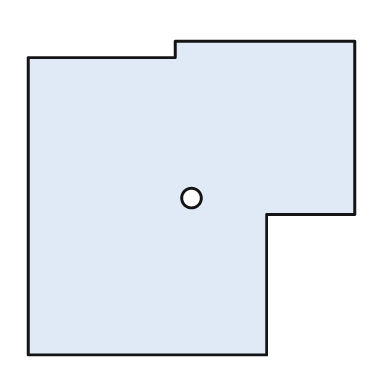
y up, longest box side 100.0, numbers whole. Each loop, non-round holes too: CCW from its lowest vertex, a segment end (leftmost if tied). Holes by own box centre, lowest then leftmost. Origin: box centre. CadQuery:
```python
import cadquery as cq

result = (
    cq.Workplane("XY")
    .moveTo(-50.0, -48.0)
    .lineTo(23.0, -48.0)
    .lineTo(23.0, -5.0)
    .lineTo(50.0, -5.0)
    .lineTo(50.0, 48.0)
    .lineTo(-5.0, 48.0)
    .lineTo(-5.0, 43.0)
    .lineTo(-50.0, 43.0)
    .close()
    .moveTo(0.0, 0.0)
    .circle(3.0)
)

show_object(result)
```